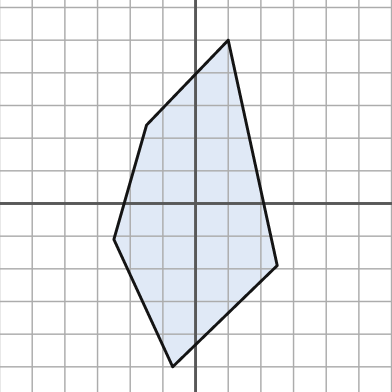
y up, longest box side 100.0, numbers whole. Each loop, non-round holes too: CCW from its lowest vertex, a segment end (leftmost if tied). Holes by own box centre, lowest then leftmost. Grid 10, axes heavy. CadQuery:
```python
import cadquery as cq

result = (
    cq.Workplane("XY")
    .moveTo(-7.0, -50.0)
    .lineTo(25.0, -19.0)
    .lineTo(10.0, 50.0)
    .lineTo(-15.0, 24.0)
    .lineTo(-25.0, -11.0)
    .close()
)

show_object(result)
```